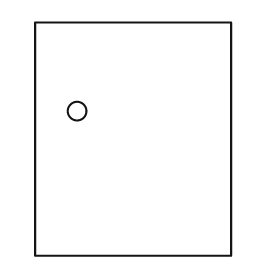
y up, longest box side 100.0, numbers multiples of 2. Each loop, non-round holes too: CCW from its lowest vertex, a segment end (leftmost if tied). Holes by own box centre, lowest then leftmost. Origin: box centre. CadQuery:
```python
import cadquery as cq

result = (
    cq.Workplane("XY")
    .moveTo(-42.0, -50.0)
    .lineTo(42.0, -50.0)
    .lineTo(42.0, 50.0)
    .lineTo(-42.0, 50.0)
    .close()
    .moveTo(-24.0, 12.0)
    .circle(4.0)
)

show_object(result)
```